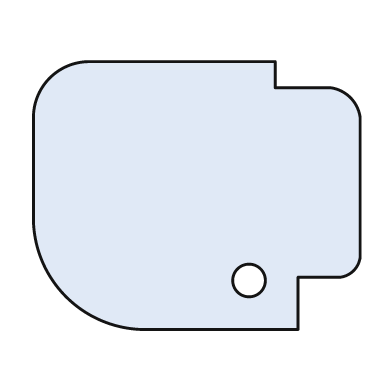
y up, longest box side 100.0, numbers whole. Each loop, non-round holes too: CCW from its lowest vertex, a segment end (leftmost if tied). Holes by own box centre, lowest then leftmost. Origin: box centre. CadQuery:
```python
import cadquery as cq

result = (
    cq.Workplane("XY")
    .moveTo(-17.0, -41.0)
    .lineTo(31.0, -41.0)
    .lineTo(31.0, -25.0)
    .lineTo(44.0, -25.0)
    .threePointArc((48.0, -23.0), (50.0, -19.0))
    .lineTo(50.0, 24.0)
    .threePointArc((47.0, 30.0), (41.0, 33.0))
    .lineTo(24.0, 33.0)
    .lineTo(24.0, 41.0)
    .lineTo(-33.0, 41.0)
    .threePointArc((-45.0, 36.0), (-50.0, 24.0))
    .lineTo(-50.0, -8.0)
    .threePointArc((-40.0, -31.0), (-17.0, -41.0))
    .close()
    .moveTo(16.0, -26.0)
    .circle(5.0)
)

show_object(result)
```